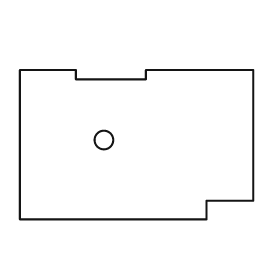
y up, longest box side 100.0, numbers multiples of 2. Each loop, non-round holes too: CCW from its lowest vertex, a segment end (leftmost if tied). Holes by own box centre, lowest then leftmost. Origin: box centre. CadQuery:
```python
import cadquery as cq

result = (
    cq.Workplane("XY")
    .moveTo(-50.0, -32.0)
    .lineTo(30.0, -32.0)
    .lineTo(30.0, -24.0)
    .lineTo(50.0, -24.0)
    .lineTo(50.0, 32.0)
    .lineTo(4.0, 32.0)
    .lineTo(4.0, 28.0)
    .lineTo(-26.0, 28.0)
    .lineTo(-26.0, 32.0)
    .lineTo(-50.0, 32.0)
    .close()
    .moveTo(-14.0, 2.0)
    .circle(4.0)
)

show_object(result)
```